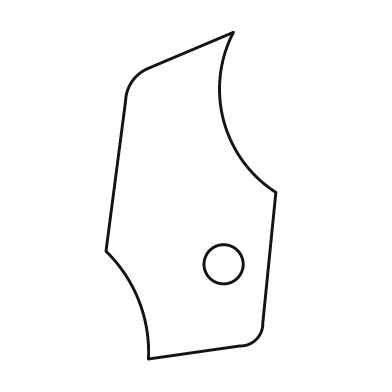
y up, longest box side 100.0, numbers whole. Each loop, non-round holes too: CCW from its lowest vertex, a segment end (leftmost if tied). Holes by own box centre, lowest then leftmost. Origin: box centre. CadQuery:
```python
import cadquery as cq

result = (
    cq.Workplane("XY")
    .moveTo(-13.0, -50.0)
    .lineTo(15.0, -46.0)
    .threePointArc((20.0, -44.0), (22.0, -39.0))
    .lineTo(26.0, 1.0)
    .threePointArc((10.0, 23.0), (13.0, 50.0))
    .lineTo(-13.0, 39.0)
    .threePointArc((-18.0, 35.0), (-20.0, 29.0))
    .lineTo(-26.0, -17.0)
    .threePointArc((-16.0, -32.0), (-13.0, -50.0))
    .close()
    .moveTo(10.0, -21.0)
    .circle(6.0)
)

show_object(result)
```